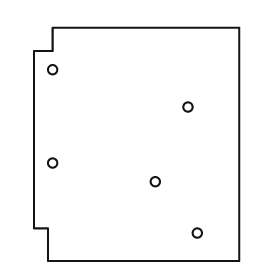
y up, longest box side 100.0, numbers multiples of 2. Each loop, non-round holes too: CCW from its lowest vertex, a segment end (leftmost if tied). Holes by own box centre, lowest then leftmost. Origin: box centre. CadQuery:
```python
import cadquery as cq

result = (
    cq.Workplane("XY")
    .moveTo(-38.0, -50.0)
    .lineTo(44.0, -50.0)
    .lineTo(44.0, 50.0)
    .lineTo(-36.0, 50.0)
    .lineTo(-36.0, 40.0)
    .lineTo(-44.0, 40.0)
    .lineTo(-44.0, -36.0)
    .lineTo(-38.0, -36.0)
    .close()
    .moveTo(26.0, -38.0)
    .circle(2.0)
    .moveTo(8.0, -16.0)
    .circle(2.0)
    .moveTo(-36.0, -8.0)
    .circle(2.0)
    .moveTo(22.0, 16.0)
    .circle(2.0)
    .moveTo(-36.0, 32.0)
    .circle(2.0)
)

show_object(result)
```